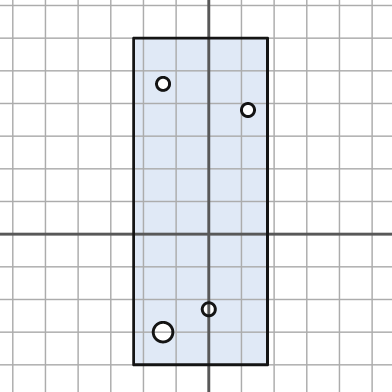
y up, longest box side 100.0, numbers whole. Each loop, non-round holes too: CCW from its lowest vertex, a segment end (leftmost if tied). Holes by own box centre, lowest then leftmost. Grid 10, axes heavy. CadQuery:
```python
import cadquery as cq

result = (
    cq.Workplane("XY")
    .moveTo(-23.0, -40.0)
    .lineTo(18.0, -40.0)
    .lineTo(18.0, 60.0)
    .lineTo(-23.0, 60.0)
    .close()
    .moveTo(-14.0, -30.0)
    .circle(3.0)
    .moveTo(0.0, -23.0)
    .circle(2.0)
    .moveTo(12.0, 38.0)
    .circle(2.0)
    .moveTo(-14.0, 46.0)
    .circle(2.0)
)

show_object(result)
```